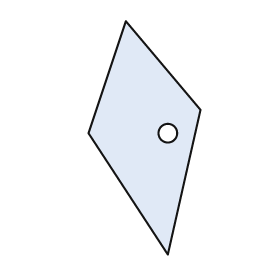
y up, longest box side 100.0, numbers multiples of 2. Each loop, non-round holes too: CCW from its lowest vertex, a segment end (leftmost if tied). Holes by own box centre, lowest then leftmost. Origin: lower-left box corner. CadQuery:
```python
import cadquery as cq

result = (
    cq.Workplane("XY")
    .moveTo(34.0, 0.0)
    .lineTo(48.0, 62.0)
    .lineTo(16.0, 100.0)
    .lineTo(0.0, 52.0)
    .close()
    .moveTo(34.0, 52.0)
    .circle(4.0)
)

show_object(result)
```